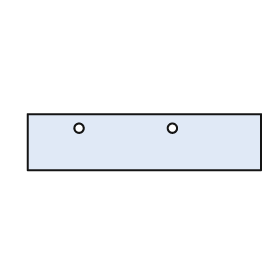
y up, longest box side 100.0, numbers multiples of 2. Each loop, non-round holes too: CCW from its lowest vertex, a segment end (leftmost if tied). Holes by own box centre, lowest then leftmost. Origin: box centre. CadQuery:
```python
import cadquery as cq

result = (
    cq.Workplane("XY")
    .moveTo(-50.0, -12.0)
    .lineTo(50.0, -12.0)
    .lineTo(50.0, 12.0)
    .lineTo(-50.0, 12.0)
    .close()
    .moveTo(-28.0, 6.0)
    .circle(2.0)
    .moveTo(12.0, 6.0)
    .circle(2.0)
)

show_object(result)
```